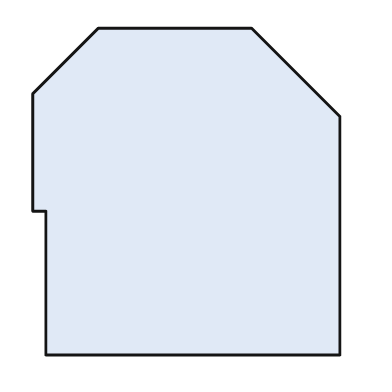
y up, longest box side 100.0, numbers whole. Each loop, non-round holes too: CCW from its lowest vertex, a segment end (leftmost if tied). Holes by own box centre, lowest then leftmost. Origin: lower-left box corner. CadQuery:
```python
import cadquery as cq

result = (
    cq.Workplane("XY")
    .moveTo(4.0, 0.0)
    .lineTo(94.0, 0.0)
    .lineTo(94.0, 73.0)
    .lineTo(67.0, 100.0)
    .lineTo(20.0, 100.0)
    .lineTo(0.0, 80.0)
    .lineTo(0.0, 44.0)
    .lineTo(4.0, 44.0)
    .close()
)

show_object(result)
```